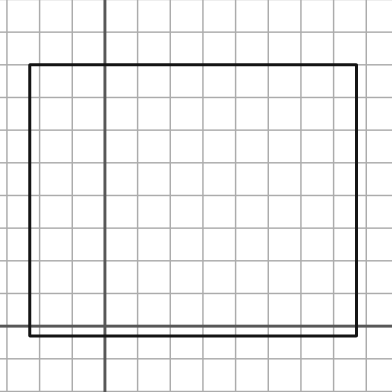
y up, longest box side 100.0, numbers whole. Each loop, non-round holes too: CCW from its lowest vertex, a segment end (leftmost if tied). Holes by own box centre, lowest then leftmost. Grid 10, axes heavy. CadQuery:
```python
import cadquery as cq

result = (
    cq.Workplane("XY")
    .moveTo(-23.0, -3.0)
    .lineTo(77.0, -3.0)
    .lineTo(77.0, 80.0)
    .lineTo(-23.0, 80.0)
    .close()
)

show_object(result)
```